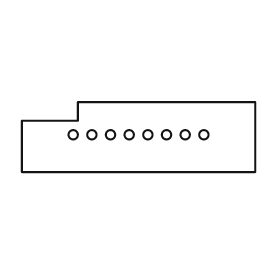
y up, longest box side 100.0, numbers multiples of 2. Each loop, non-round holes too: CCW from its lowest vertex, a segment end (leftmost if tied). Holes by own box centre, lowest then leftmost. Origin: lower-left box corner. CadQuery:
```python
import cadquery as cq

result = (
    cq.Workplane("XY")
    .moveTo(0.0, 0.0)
    .lineTo(100.0, 0.0)
    .lineTo(100.0, 30.0)
    .lineTo(24.0, 30.0)
    .lineTo(24.0, 22.0)
    .lineTo(0.0, 22.0)
    .close()
    .moveTo(22.0, 16.0)
    .circle(2.0)
    .moveTo(30.0, 16.0)
    .circle(2.0)
    .moveTo(38.0, 16.0)
    .circle(2.0)
    .moveTo(46.0, 16.0)
    .circle(2.0)
    .moveTo(54.0, 16.0)
    .circle(2.0)
    .moveTo(62.0, 16.0)
    .circle(2.0)
    .moveTo(70.0, 16.0)
    .circle(2.0)
    .moveTo(78.0, 16.0)
    .circle(2.0)
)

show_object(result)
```